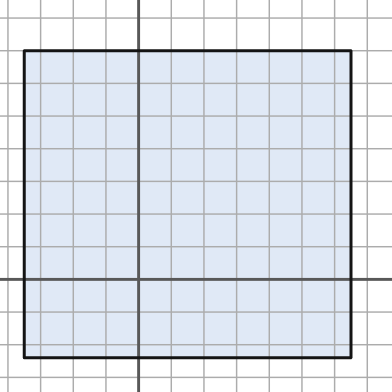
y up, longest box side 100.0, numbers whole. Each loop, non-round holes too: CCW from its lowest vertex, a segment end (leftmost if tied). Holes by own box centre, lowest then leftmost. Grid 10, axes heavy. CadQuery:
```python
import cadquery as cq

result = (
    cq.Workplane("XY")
    .moveTo(-35.0, -24.0)
    .lineTo(65.0, -24.0)
    .lineTo(65.0, 70.0)
    .lineTo(-35.0, 70.0)
    .close()
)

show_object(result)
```